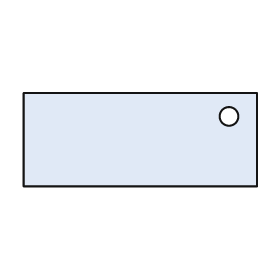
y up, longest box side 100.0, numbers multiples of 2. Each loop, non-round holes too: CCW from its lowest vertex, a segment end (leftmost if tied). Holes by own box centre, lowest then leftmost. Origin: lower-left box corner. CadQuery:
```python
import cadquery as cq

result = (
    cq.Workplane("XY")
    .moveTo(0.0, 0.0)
    .lineTo(100.0, 0.0)
    .lineTo(100.0, 40.0)
    .lineTo(0.0, 40.0)
    .close()
    .moveTo(88.0, 30.0)
    .circle(4.0)
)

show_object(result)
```